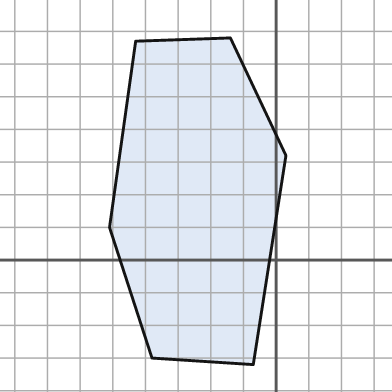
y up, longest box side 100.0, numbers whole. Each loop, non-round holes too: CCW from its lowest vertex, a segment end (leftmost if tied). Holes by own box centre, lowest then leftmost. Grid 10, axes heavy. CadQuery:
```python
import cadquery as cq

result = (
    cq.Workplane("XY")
    .moveTo(-7.0, -32.0)
    .lineTo(3.0, 32.0)
    .lineTo(-14.0, 68.0)
    .lineTo(-43.0, 67.0)
    .lineTo(-51.0, 10.0)
    .lineTo(-38.0, -30.0)
    .close()
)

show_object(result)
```